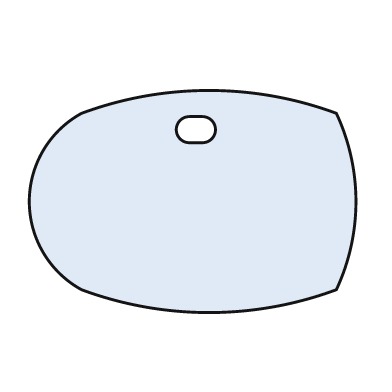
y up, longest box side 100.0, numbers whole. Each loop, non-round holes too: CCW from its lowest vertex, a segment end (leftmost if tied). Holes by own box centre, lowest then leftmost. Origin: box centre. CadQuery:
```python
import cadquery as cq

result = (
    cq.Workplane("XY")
    .moveTo(-34.0, -27.0)
    .threePointArc((5.0, -34.0), (44.0, -27.0))
    .threePointArc((50.0, 0.0), (44.0, 27.0))
    .threePointArc((5.0, 34.0), (-34.0, 27.0))
    .threePointArc((-50.0, 0.0), (-34.0, -27.0))
    .close()
    .moveTo(-1.0, 18.0)
    .lineTo(3.0, 18.0)
    .threePointArc((7.0, 22.0), (3.0, 26.0))
    .lineTo(-1.0, 26.0)
    .threePointArc((-5.0, 22.0), (-1.0, 18.0))
    .close()
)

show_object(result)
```